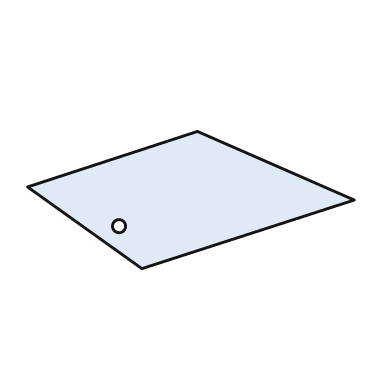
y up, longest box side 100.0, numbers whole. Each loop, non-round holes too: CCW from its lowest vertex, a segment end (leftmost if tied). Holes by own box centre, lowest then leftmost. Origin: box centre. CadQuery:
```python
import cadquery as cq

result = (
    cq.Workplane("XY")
    .moveTo(-15.0, -21.0)
    .lineTo(50.0, 0.0)
    .lineTo(2.0, 21.0)
    .lineTo(-50.0, 4.0)
    .close()
    .moveTo(-22.0, -8.0)
    .circle(2.0)
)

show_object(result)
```